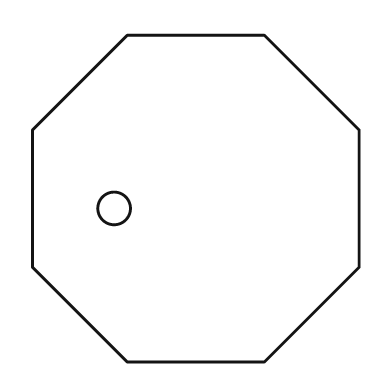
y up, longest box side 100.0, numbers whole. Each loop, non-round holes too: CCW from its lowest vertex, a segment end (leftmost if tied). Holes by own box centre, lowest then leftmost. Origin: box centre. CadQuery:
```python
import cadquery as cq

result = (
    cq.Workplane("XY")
    .moveTo(-21.0, -50.0)
    .lineTo(21.0, -50.0)
    .lineTo(50.0, -21.0)
    .lineTo(50.0, 21.0)
    .lineTo(21.0, 50.0)
    .lineTo(-21.0, 50.0)
    .lineTo(-50.0, 21.0)
    .lineTo(-50.0, -21.0)
    .close()
    .moveTo(-25.0, -3.0)
    .circle(5.0)
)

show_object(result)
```